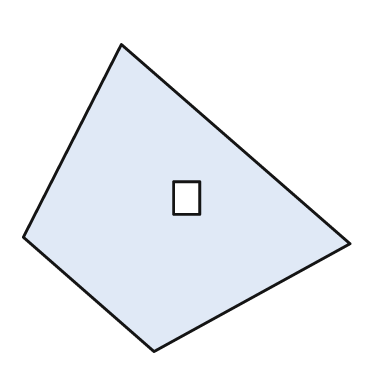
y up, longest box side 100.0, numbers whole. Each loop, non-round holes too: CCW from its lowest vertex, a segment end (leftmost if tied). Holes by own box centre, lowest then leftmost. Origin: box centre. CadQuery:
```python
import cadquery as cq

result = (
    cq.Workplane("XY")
    .moveTo(-10.0, -47.0)
    .lineTo(50.0, -14.0)
    .lineTo(-20.0, 47.0)
    .lineTo(-50.0, -12.0)
    .close()
    .moveTo(-4.0, -5.0)
    .lineTo(4.0, -5.0)
    .lineTo(4.0, 5.0)
    .lineTo(-4.0, 5.0)
    .close()
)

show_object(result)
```